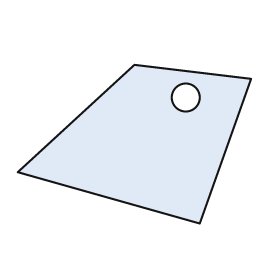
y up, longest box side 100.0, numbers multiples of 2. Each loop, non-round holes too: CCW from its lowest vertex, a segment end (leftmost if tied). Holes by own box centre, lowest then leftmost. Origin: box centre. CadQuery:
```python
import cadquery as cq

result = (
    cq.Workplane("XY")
    .moveTo(28.0, -34.0)
    .lineTo(50.0, 28.0)
    .lineTo(0.0, 34.0)
    .lineTo(-50.0, -12.0)
    .close()
    .moveTo(22.0, 20.0)
    .circle(6.0)
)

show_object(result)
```